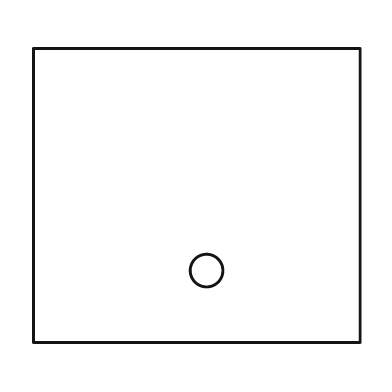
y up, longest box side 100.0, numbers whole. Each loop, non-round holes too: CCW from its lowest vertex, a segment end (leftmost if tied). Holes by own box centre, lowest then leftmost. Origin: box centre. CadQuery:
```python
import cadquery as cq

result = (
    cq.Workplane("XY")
    .moveTo(-50.0, -45.0)
    .lineTo(50.0, -45.0)
    .lineTo(50.0, 45.0)
    .lineTo(-50.0, 45.0)
    .close()
    .moveTo(3.0, -23.0)
    .circle(5.0)
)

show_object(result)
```